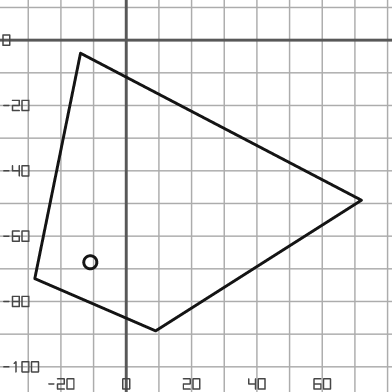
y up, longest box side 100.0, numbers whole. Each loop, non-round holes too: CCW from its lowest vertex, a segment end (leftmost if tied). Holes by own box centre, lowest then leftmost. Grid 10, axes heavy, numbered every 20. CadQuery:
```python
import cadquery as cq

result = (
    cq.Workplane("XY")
    .moveTo(9.0, -89.0)
    .lineTo(72.0, -49.0)
    .lineTo(-14.0, -4.0)
    .lineTo(-28.0, -73.0)
    .close()
    .moveTo(-11.0, -68.0)
    .circle(2.0)
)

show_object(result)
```